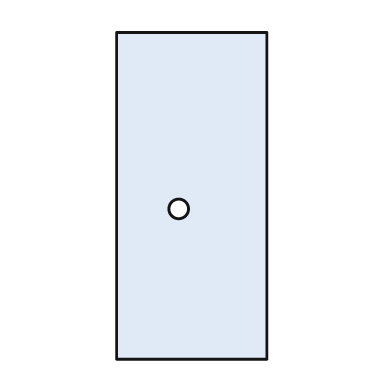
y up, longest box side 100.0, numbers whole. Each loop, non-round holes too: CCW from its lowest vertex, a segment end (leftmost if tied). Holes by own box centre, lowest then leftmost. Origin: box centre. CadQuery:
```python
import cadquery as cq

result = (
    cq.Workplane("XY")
    .moveTo(-23.0, -50.0)
    .lineTo(23.0, -50.0)
    .lineTo(23.0, 50.0)
    .lineTo(-23.0, 50.0)
    .close()
    .moveTo(-4.0, -4.0)
    .circle(3.0)
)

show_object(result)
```